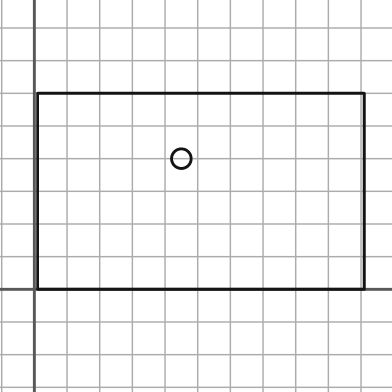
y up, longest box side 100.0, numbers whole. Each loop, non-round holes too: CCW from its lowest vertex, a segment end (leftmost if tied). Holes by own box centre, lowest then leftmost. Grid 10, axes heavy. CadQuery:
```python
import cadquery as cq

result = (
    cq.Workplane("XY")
    .moveTo(1.0, 0.0)
    .lineTo(101.0, 0.0)
    .lineTo(101.0, 60.0)
    .lineTo(1.0, 60.0)
    .close()
    .moveTo(45.0, 40.0)
    .circle(3.0)
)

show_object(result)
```